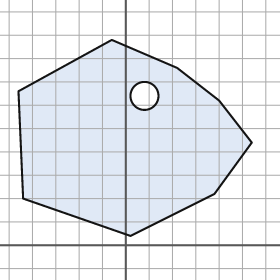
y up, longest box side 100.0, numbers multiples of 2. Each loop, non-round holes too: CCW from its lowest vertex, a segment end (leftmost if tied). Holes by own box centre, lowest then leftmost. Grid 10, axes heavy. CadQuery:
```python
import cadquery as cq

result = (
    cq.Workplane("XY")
    .moveTo(2.0, 4.0)
    .lineTo(38.0, 22.0)
    .lineTo(54.0, 44.0)
    .lineTo(40.0, 62.0)
    .lineTo(22.0, 76.0)
    .lineTo(-6.0, 88.0)
    .lineTo(-46.0, 66.0)
    .lineTo(-44.0, 20.0)
    .close()
    .moveTo(8.0, 64.0)
    .circle(6.0)
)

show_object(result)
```